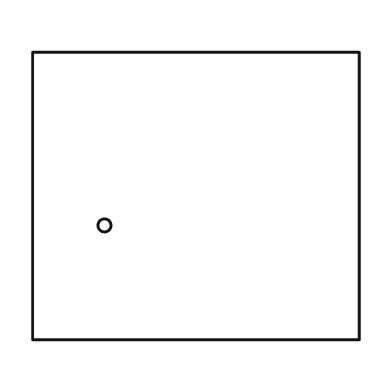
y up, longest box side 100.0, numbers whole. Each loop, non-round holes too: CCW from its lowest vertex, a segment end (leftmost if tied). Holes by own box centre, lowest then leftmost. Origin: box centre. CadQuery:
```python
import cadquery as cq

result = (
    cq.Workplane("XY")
    .moveTo(-50.0, -44.0)
    .lineTo(50.0, -44.0)
    .lineTo(50.0, 44.0)
    .lineTo(-50.0, 44.0)
    .close()
    .moveTo(-28.0, -9.0)
    .circle(2.0)
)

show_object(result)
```